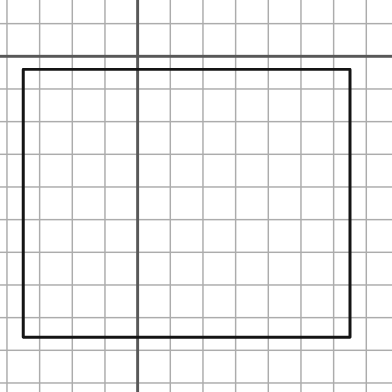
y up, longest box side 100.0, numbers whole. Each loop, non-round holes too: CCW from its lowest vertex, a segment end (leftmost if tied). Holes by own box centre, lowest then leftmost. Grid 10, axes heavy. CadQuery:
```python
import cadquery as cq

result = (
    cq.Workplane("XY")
    .moveTo(-35.0, -86.0)
    .lineTo(65.0, -86.0)
    .lineTo(65.0, -4.0)
    .lineTo(-35.0, -4.0)
    .close()
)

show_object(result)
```